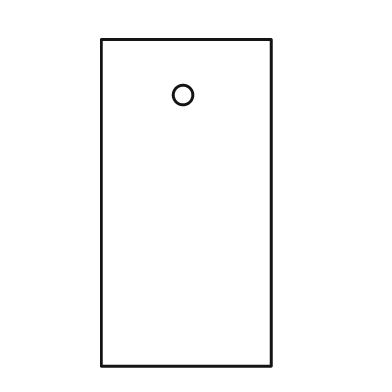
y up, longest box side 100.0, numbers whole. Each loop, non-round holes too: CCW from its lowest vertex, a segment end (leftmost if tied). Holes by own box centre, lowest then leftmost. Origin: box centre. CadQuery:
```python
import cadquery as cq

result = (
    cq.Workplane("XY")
    .moveTo(-26.0, -50.0)
    .lineTo(26.0, -50.0)
    .lineTo(26.0, 50.0)
    .lineTo(-26.0, 50.0)
    .close()
    .moveTo(-1.0, 33.0)
    .circle(3.0)
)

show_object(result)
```